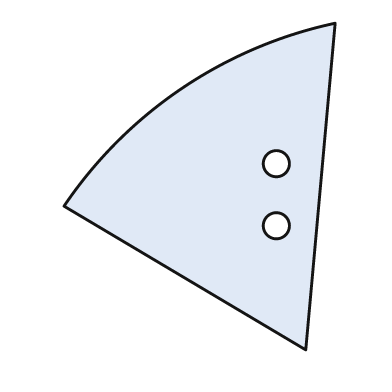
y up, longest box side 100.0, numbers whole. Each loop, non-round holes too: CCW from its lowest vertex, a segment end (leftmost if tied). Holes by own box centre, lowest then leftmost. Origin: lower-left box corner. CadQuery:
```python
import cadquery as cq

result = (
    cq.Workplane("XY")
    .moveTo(74.0, 0.0)
    .lineTo(83.0, 100.0)
    .threePointArc((36.0, 80.0), (0.0, 44.0))
    .close()
    .moveTo(65.0, 38.0)
    .circle(4.0)
    .moveTo(65.0, 57.0)
    .circle(4.0)
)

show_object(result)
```